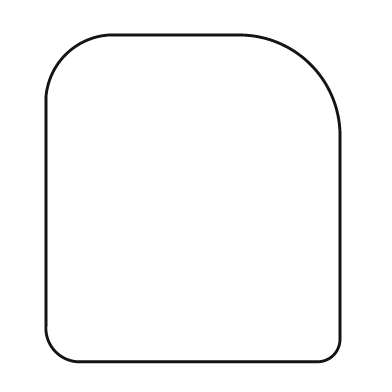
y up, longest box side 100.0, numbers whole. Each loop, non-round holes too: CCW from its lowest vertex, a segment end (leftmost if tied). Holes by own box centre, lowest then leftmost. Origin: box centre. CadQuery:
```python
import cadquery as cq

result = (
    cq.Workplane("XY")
    .moveTo(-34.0, -50.0)
    .lineTo(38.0, -50.0)
    .threePointArc((43.0, -48.0), (45.0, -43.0))
    .lineTo(45.0, 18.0)
    .threePointArc((36.0, 41.0), (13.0, 50.0))
    .lineTo(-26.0, 50.0)
    .threePointArc((-39.0, 44.0), (-45.0, 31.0))
    .lineTo(-45.0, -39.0)
    .threePointArc((-42.0, -47.0), (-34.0, -50.0))
    .close()
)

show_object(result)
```